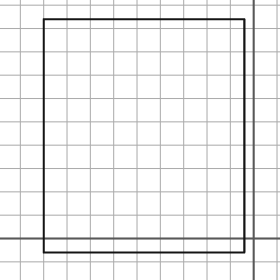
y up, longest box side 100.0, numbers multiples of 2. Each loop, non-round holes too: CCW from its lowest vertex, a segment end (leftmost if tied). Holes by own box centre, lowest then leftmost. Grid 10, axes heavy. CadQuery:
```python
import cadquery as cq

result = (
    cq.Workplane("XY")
    .moveTo(-90.0, -6.0)
    .lineTo(-4.0, -6.0)
    .lineTo(-4.0, 94.0)
    .lineTo(-90.0, 94.0)
    .close()
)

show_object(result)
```